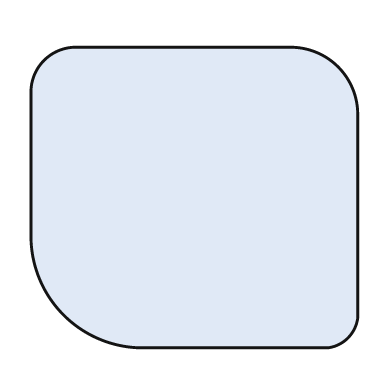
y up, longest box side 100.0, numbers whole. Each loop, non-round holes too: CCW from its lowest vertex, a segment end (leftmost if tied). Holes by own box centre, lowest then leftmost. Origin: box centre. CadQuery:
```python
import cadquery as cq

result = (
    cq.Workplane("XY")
    .moveTo(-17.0, -46.0)
    .lineTo(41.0, -46.0)
    .threePointArc((47.0, -43.0), (50.0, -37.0))
    .lineTo(50.0, 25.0)
    .threePointArc((44.0, 40.0), (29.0, 46.0))
    .lineTo(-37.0, 46.0)
    .threePointArc((-46.0, 42.0), (-50.0, 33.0))
    .lineTo(-50.0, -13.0)
    .threePointArc((-40.0, -36.0), (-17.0, -46.0))
    .close()
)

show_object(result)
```